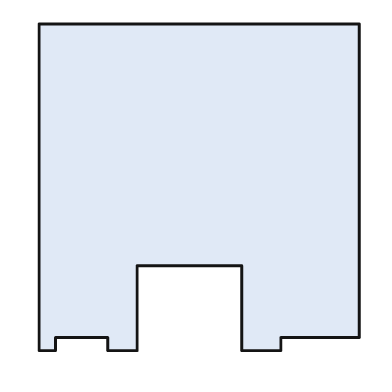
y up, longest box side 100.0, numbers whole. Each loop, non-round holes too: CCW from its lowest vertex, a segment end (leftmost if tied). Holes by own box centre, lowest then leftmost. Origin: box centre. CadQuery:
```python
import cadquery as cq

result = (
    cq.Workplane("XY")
    .moveTo(-49.0, -50.0)
    .lineTo(-44.0, -50.0)
    .lineTo(-44.0, -46.0)
    .lineTo(-28.0, -46.0)
    .lineTo(-28.0, -50.0)
    .lineTo(-19.0, -50.0)
    .lineTo(-19.0, -24.0)
    .lineTo(13.0, -24.0)
    .lineTo(13.0, -50.0)
    .lineTo(25.0, -50.0)
    .lineTo(25.0, -46.0)
    .lineTo(49.0, -46.0)
    .lineTo(49.0, 50.0)
    .lineTo(-49.0, 50.0)
    .close()
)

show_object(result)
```